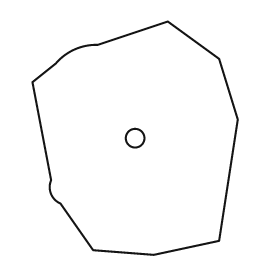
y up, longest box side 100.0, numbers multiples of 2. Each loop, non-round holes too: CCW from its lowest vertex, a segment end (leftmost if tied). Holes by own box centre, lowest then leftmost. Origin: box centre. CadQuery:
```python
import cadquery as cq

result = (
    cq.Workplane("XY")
    .moveTo(8.0, -50.0)
    .lineTo(36.0, -44.0)
    .lineTo(44.0, 8.0)
    .lineTo(36.0, 34.0)
    .lineTo(14.0, 50.0)
    .lineTo(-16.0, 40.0)
    .threePointArc((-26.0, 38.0), (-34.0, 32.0))
    .lineTo(-44.0, 24.0)
    .lineTo(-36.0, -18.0)
    .threePointArc((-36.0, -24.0), (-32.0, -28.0))
    .lineTo(-18.0, -48.0)
    .close()
    .moveTo(0.0, 0.0)
    .circle(4.0)
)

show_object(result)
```